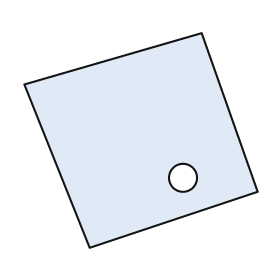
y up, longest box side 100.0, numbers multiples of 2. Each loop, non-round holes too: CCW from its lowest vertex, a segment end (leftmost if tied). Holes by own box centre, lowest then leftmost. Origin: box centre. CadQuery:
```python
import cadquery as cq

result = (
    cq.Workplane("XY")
    .moveTo(-22.0, -46.0)
    .lineTo(50.0, -22.0)
    .lineTo(26.0, 46.0)
    .lineTo(-50.0, 24.0)
    .close()
    .moveTo(18.0, -16.0)
    .circle(6.0)
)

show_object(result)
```